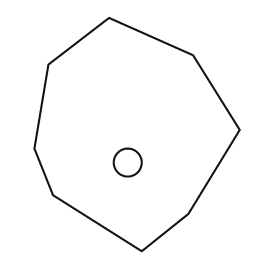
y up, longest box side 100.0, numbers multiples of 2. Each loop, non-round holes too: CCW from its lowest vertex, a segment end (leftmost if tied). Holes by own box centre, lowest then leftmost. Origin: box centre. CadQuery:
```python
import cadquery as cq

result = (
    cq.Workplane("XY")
    .moveTo(2.0, -50.0)
    .lineTo(22.0, -34.0)
    .lineTo(44.0, 2.0)
    .lineTo(24.0, 34.0)
    .lineTo(-12.0, 50.0)
    .lineTo(-38.0, 30.0)
    .lineTo(-44.0, -6.0)
    .lineTo(-36.0, -26.0)
    .close()
    .moveTo(-4.0, -12.0)
    .circle(6.0)
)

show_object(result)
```